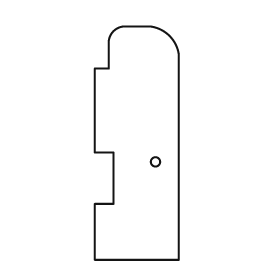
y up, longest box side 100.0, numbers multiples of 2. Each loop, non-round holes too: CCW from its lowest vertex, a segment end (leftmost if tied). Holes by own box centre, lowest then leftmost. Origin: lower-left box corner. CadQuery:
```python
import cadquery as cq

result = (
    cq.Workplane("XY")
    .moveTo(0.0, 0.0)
    .lineTo(36.0, 0.0)
    .lineTo(36.0, 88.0)
    .threePointArc((32.0, 96.0), (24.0, 100.0))
    .lineTo(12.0, 100.0)
    .threePointArc((8.0, 98.0), (6.0, 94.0))
    .lineTo(6.0, 82.0)
    .lineTo(0.0, 82.0)
    .lineTo(0.0, 46.0)
    .lineTo(8.0, 46.0)
    .lineTo(8.0, 24.0)
    .lineTo(0.0, 24.0)
    .close()
    .moveTo(26.0, 42.0)
    .circle(2.0)
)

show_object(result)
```